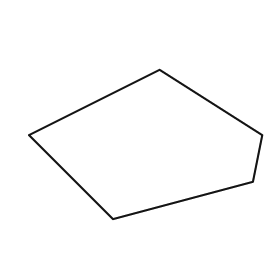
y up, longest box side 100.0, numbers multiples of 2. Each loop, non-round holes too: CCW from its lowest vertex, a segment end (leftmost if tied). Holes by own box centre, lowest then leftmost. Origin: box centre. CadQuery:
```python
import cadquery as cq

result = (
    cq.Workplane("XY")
    .moveTo(-14.0, -32.0)
    .lineTo(46.0, -16.0)
    .lineTo(50.0, 4.0)
    .lineTo(6.0, 32.0)
    .lineTo(-50.0, 4.0)
    .close()
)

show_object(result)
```